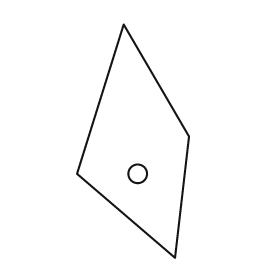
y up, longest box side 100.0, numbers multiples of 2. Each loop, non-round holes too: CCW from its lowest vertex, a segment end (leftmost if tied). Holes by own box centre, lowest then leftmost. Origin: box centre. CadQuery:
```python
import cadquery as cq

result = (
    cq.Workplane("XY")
    .moveTo(18.0, -50.0)
    .lineTo(24.0, 2.0)
    .lineTo(-4.0, 50.0)
    .lineTo(-24.0, -14.0)
    .close()
    .moveTo(2.0, -14.0)
    .circle(4.0)
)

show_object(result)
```